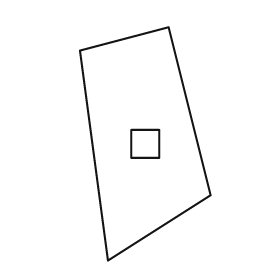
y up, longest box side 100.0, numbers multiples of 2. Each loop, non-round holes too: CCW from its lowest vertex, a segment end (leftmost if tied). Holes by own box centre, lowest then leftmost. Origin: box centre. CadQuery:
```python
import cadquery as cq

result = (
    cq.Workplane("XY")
    .moveTo(-16.0, -50.0)
    .lineTo(28.0, -22.0)
    .lineTo(10.0, 50.0)
    .lineTo(-28.0, 40.0)
    .close()
    .moveTo(-6.0, -6.0)
    .lineTo(6.0, -6.0)
    .lineTo(6.0, 6.0)
    .lineTo(-6.0, 6.0)
    .close()
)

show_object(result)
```